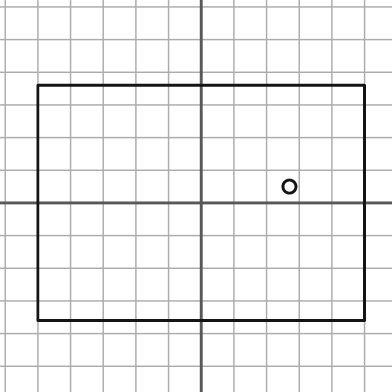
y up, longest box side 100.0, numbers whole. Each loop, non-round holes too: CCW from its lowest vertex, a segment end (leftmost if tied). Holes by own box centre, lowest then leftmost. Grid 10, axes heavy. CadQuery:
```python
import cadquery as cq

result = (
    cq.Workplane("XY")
    .moveTo(-50.0, -36.0)
    .lineTo(50.0, -36.0)
    .lineTo(50.0, 36.0)
    .lineTo(-50.0, 36.0)
    .close()
    .moveTo(27.0, 5.0)
    .circle(2.0)
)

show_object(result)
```